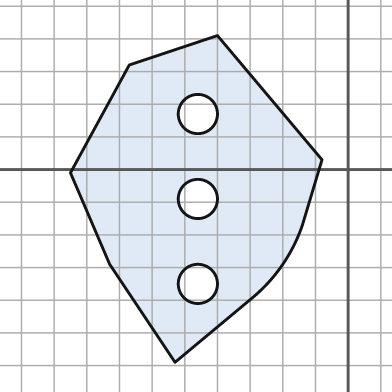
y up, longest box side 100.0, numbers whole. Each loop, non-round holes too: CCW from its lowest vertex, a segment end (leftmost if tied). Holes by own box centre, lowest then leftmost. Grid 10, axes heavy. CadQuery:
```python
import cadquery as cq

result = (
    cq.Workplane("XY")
    .moveTo(-53.0, -59.0)
    .lineTo(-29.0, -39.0)
    .threePointArc((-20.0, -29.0), (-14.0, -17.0))
    .lineTo(-8.0, 3.0)
    .lineTo(-40.0, 41.0)
    .lineTo(-67.0, 32.0)
    .lineTo(-85.0, -1.0)
    .lineTo(-73.0, -29.0)
    .close()
    .moveTo(-46.0, -35.0)
    .circle(6.0)
    .moveTo(-46.0, -9.0)
    .circle(6.0)
    .moveTo(-46.0, 17.0)
    .circle(6.0)
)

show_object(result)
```